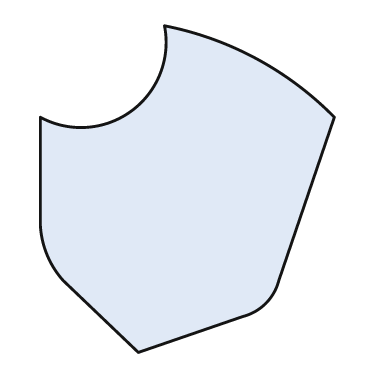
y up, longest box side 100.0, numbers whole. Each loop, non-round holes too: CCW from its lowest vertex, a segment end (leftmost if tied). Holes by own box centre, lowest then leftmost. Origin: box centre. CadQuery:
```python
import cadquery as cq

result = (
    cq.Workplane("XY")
    .moveTo(-15.0, -50.0)
    .lineTo(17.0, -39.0)
    .threePointArc((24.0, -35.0), (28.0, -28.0))
    .lineTo(45.0, 22.0)
    .threePointArc((21.0, 40.0), (-7.0, 50.0))
    .threePointArc((-17.0, 24.0), (-45.0, 22.0))
    .lineTo(-45.0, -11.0)
    .threePointArc((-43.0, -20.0), (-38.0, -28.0))
    .close()
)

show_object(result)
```